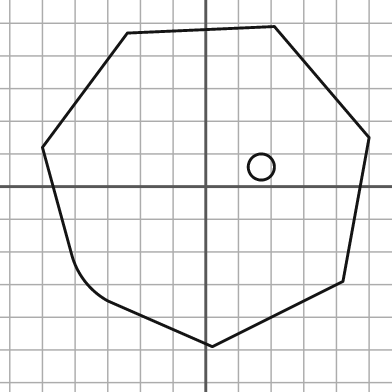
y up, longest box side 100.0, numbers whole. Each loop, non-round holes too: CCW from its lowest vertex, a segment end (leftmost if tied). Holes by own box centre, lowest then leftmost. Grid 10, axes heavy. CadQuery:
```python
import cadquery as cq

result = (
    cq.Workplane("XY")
    .moveTo(2.0, -49.0)
    .lineTo(42.0, -29.0)
    .lineTo(50.0, 15.0)
    .lineTo(21.0, 49.0)
    .lineTo(-24.0, 47.0)
    .lineTo(-50.0, 12.0)
    .lineTo(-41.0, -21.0)
    .threePointArc((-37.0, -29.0), (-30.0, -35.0))
    .close()
    .moveTo(17.0, 6.0)
    .circle(4.0)
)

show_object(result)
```